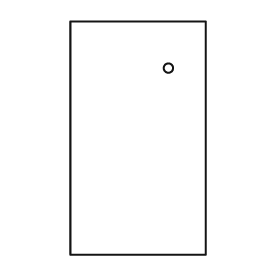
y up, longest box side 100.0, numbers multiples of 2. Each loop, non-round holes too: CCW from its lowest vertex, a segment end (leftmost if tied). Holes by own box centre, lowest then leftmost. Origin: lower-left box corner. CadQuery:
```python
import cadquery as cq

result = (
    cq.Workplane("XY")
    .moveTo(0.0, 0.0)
    .lineTo(58.0, 0.0)
    .lineTo(58.0, 100.0)
    .lineTo(0.0, 100.0)
    .close()
    .moveTo(42.0, 80.0)
    .circle(2.0)
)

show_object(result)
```